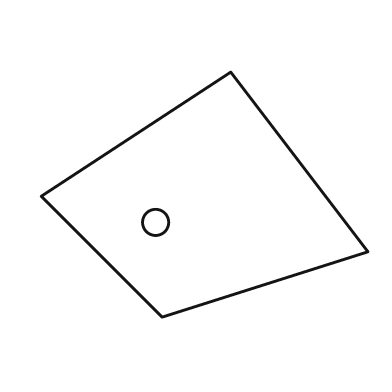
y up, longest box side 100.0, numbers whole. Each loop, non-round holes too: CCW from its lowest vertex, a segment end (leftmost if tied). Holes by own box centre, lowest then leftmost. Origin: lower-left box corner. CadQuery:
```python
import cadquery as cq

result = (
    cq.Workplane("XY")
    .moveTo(37.0, 0.0)
    .lineTo(100.0, 20.0)
    .lineTo(58.0, 75.0)
    .lineTo(0.0, 37.0)
    .close()
    .moveTo(35.0, 29.0)
    .circle(4.0)
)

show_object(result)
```